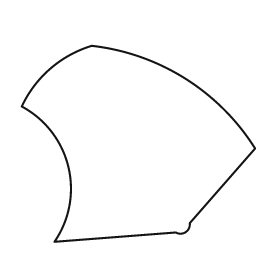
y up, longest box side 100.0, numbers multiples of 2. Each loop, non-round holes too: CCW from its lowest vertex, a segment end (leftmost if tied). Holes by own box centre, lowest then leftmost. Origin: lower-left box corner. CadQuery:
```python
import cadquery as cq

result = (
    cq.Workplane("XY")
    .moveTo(14.0, 0.0)
    .lineTo(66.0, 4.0)
    .threePointArc((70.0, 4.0), (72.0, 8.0))
    .lineTo(100.0, 40.0)
    .threePointArc((70.0, 70.0), (30.0, 84.0))
    .threePointArc((12.0, 74.0), (0.0, 58.0))
    .threePointArc((20.0, 32.0), (14.0, 0.0))
    .close()
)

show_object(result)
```